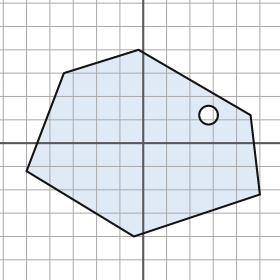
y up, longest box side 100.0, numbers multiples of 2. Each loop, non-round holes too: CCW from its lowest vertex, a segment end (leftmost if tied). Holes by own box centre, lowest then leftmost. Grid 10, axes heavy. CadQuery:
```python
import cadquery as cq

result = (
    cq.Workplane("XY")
    .moveTo(-4.0, -40.0)
    .lineTo(50.0, -22.0)
    .lineTo(46.0, 12.0)
    .lineTo(-2.0, 40.0)
    .lineTo(-34.0, 30.0)
    .lineTo(-50.0, -12.0)
    .close()
    .moveTo(28.0, 12.0)
    .circle(4.0)
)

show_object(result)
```